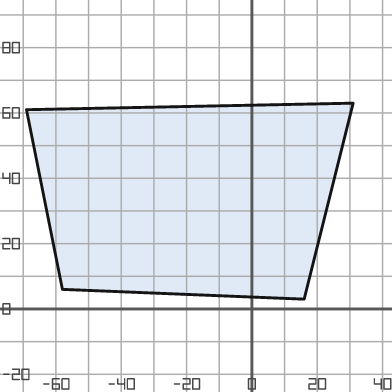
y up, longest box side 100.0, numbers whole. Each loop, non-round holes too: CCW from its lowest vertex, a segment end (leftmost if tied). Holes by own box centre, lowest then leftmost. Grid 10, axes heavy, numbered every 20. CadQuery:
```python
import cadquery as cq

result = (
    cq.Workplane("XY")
    .moveTo(16.0, 3.0)
    .lineTo(31.0, 63.0)
    .lineTo(-69.0, 61.0)
    .lineTo(-58.0, 6.0)
    .close()
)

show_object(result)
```